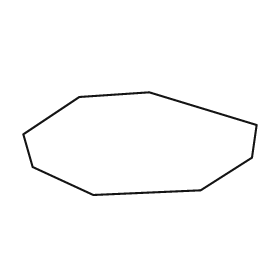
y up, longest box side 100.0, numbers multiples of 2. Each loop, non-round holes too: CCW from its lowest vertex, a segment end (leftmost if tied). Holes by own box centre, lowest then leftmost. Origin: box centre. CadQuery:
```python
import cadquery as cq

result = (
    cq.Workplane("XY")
    .moveTo(-20.0, -22.0)
    .lineTo(26.0, -20.0)
    .lineTo(48.0, -6.0)
    .lineTo(50.0, 8.0)
    .lineTo(4.0, 22.0)
    .lineTo(-26.0, 20.0)
    .lineTo(-50.0, 4.0)
    .lineTo(-46.0, -10.0)
    .close()
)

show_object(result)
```